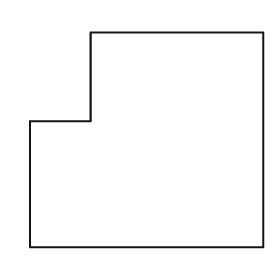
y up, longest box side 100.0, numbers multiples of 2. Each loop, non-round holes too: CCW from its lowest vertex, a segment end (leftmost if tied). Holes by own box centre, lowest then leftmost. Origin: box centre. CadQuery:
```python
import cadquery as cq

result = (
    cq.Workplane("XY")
    .moveTo(-50.0, -46.0)
    .lineTo(50.0, -46.0)
    .lineTo(50.0, 46.0)
    .lineTo(-24.0, 46.0)
    .lineTo(-24.0, 8.0)
    .lineTo(-50.0, 8.0)
    .close()
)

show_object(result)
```